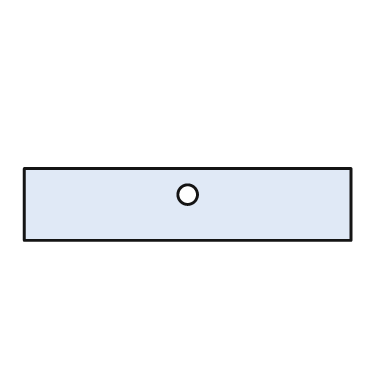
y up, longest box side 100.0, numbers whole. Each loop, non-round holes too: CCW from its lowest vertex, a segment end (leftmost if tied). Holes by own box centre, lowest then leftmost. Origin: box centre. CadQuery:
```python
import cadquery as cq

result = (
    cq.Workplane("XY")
    .moveTo(-50.0, -11.0)
    .lineTo(50.0, -11.0)
    .lineTo(50.0, 11.0)
    .lineTo(-50.0, 11.0)
    .close()
    .moveTo(0.0, 3.0)
    .circle(3.0)
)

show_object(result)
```